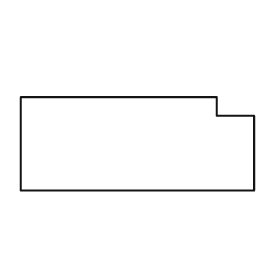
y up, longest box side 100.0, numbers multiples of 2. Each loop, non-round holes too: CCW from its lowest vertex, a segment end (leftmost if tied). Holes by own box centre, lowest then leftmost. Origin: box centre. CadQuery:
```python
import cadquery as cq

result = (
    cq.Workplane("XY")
    .moveTo(-50.0, -20.0)
    .lineTo(50.0, -20.0)
    .lineTo(50.0, 12.0)
    .lineTo(34.0, 12.0)
    .lineTo(34.0, 20.0)
    .lineTo(-50.0, 20.0)
    .close()
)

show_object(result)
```